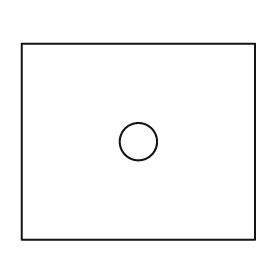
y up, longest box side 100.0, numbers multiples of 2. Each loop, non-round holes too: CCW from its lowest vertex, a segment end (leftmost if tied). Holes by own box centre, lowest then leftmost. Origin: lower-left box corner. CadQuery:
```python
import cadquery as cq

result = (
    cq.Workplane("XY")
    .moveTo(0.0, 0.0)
    .lineTo(100.0, 0.0)
    .lineTo(100.0, 84.0)
    .lineTo(0.0, 84.0)
    .close()
    .moveTo(50.0, 42.0)
    .circle(8.0)
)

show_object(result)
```